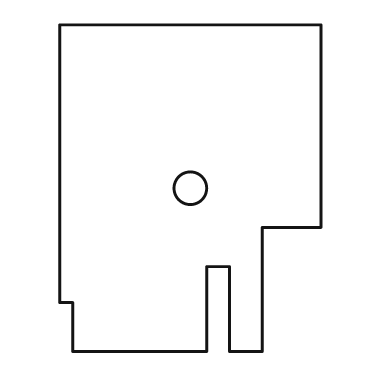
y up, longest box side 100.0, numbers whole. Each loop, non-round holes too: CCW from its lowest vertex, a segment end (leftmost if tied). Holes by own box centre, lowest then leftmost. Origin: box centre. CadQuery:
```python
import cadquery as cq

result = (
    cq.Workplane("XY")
    .moveTo(-36.0, -50.0)
    .lineTo(5.0, -50.0)
    .lineTo(5.0, -24.0)
    .lineTo(12.0, -24.0)
    .lineTo(12.0, -50.0)
    .lineTo(22.0, -50.0)
    .lineTo(22.0, -12.0)
    .lineTo(40.0, -12.0)
    .lineTo(40.0, 50.0)
    .lineTo(-40.0, 50.0)
    .lineTo(-40.0, -35.0)
    .lineTo(-36.0, -35.0)
    .close()
    .moveTo(0.0, 0.0)
    .circle(5.0)
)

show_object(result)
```